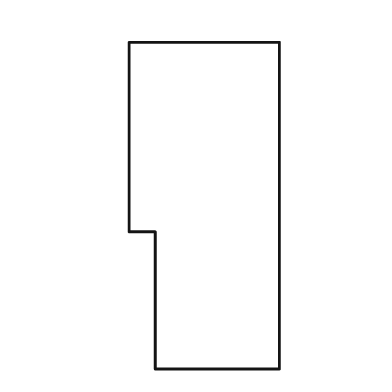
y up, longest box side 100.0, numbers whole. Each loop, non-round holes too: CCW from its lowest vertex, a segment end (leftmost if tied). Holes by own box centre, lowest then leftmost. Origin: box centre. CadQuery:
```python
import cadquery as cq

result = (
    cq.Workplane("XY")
    .moveTo(-15.0, -50.0)
    .lineTo(23.0, -50.0)
    .lineTo(23.0, 50.0)
    .lineTo(-23.0, 50.0)
    .lineTo(-23.0, -8.0)
    .lineTo(-15.0, -8.0)
    .close()
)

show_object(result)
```